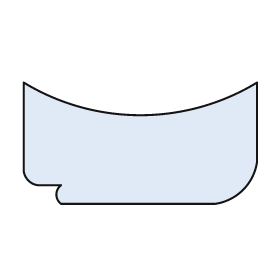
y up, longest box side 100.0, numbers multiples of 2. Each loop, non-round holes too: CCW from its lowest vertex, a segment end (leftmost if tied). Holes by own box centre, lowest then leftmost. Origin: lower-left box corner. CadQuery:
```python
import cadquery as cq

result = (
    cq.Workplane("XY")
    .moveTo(16.0, 0.0)
    .lineTo(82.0, 0.0)
    .threePointArc((94.0, 6.0), (100.0, 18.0))
    .lineTo(100.0, 52.0)
    .threePointArc((50.0, 38.0), (0.0, 52.0))
    .lineTo(0.0, 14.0)
    .threePointArc((2.0, 10.0), (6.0, 8.0))
    .lineTo(16.0, 8.0)
    .threePointArc((14.0, 4.0), (16.0, 0.0))
    .close()
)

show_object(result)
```